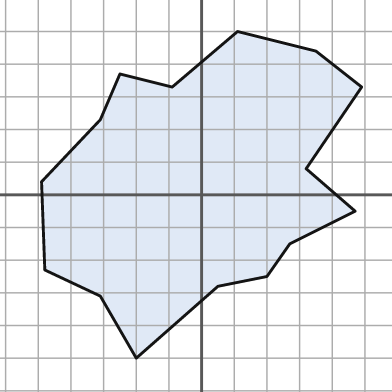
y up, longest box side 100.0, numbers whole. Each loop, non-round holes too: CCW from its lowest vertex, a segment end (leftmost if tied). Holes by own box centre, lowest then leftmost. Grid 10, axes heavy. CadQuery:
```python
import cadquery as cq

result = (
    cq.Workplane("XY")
    .moveTo(-20.0, -50.0)
    .lineTo(5.0, -28.0)
    .lineTo(20.0, -25.0)
    .lineTo(27.0, -15.0)
    .lineTo(47.0, -5.0)
    .lineTo(32.0, 8.0)
    .lineTo(49.0, 33.0)
    .lineTo(35.0, 44.0)
    .lineTo(11.0, 50.0)
    .lineTo(-9.0, 33.0)
    .lineTo(-25.0, 37.0)
    .lineTo(-31.0, 23.0)
    .lineTo(-49.0, 4.0)
    .lineTo(-48.0, -23.0)
    .lineTo(-31.0, -31.0)
    .close()
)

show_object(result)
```